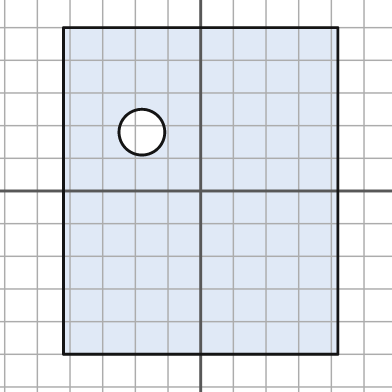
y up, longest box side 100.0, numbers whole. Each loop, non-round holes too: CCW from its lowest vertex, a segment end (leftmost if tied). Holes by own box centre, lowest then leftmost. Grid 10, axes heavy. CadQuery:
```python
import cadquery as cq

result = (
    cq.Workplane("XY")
    .moveTo(-42.0, -50.0)
    .lineTo(42.0, -50.0)
    .lineTo(42.0, 50.0)
    .lineTo(-42.0, 50.0)
    .close()
    .moveTo(-18.0, 18.0)
    .circle(7.0)
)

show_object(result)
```